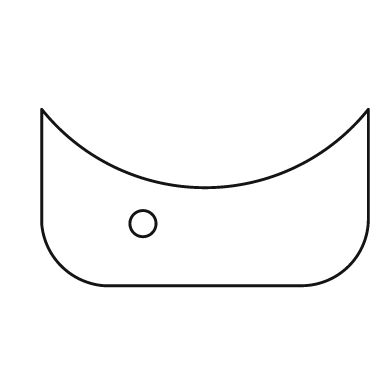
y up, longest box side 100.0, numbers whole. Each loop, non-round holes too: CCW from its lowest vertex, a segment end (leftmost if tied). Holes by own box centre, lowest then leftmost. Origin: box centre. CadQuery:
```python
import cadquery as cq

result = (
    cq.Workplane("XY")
    .moveTo(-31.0, -27.0)
    .lineTo(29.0, -27.0)
    .threePointArc((44.0, -21.0), (50.0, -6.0))
    .lineTo(50.0, 27.0)
    .threePointArc((0.0, 3.0), (-50.0, 27.0))
    .lineTo(-50.0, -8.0)
    .threePointArc((-44.0, -21.0), (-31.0, -27.0))
    .close()
    .moveTo(-19.0, -8.0)
    .circle(4.0)
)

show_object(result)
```